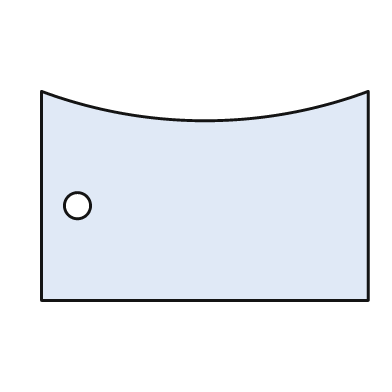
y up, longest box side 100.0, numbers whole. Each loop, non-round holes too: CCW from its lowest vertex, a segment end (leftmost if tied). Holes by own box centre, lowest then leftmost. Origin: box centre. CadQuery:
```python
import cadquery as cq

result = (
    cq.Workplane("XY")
    .moveTo(-50.0, -32.0)
    .lineTo(50.0, -32.0)
    .lineTo(50.0, 32.0)
    .threePointArc((0.0, 23.0), (-50.0, 32.0))
    .close()
    .moveTo(-39.0, -3.0)
    .circle(4.0)
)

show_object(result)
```